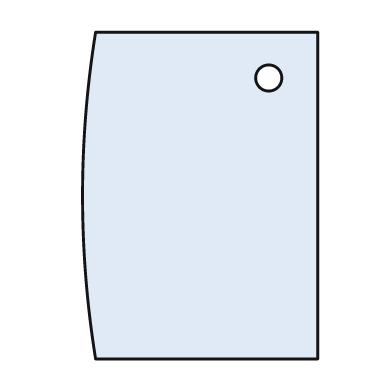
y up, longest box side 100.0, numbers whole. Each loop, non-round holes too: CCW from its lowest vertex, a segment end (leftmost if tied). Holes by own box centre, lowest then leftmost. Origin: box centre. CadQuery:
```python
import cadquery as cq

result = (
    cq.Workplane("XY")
    .moveTo(-32.0, -50.0)
    .lineTo(36.0, -50.0)
    .lineTo(36.0, 50.0)
    .lineTo(-32.0, 50.0)
    .threePointArc((-36.0, 0.0), (-32.0, -50.0))
    .close()
    .moveTo(21.0, 36.0)
    .circle(4.0)
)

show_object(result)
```